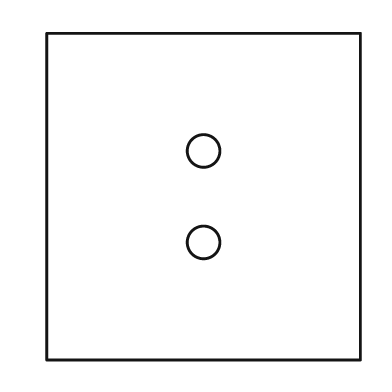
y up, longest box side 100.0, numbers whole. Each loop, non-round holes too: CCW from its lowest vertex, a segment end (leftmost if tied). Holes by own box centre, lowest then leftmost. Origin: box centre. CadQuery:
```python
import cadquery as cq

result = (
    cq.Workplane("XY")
    .moveTo(-48.0, -50.0)
    .lineTo(48.0, -50.0)
    .lineTo(48.0, 50.0)
    .lineTo(-48.0, 50.0)
    .close()
    .moveTo(0.0, -14.0)
    .circle(5.0)
    .moveTo(0.0, 14.0)
    .circle(5.0)
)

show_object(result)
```